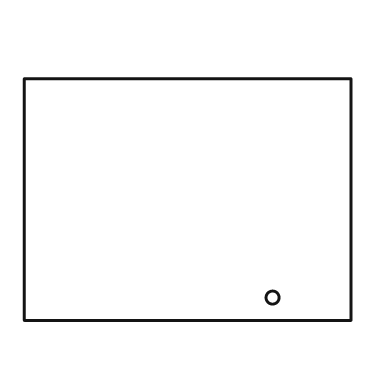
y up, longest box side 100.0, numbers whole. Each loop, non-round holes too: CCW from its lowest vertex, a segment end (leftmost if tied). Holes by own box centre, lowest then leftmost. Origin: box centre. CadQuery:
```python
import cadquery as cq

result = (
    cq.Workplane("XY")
    .moveTo(-50.0, -37.0)
    .lineTo(50.0, -37.0)
    .lineTo(50.0, 37.0)
    .lineTo(-50.0, 37.0)
    .close()
    .moveTo(26.0, -30.0)
    .circle(2.0)
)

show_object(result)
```